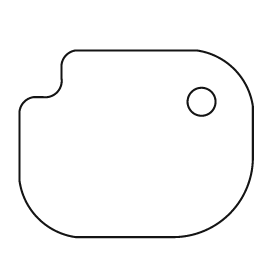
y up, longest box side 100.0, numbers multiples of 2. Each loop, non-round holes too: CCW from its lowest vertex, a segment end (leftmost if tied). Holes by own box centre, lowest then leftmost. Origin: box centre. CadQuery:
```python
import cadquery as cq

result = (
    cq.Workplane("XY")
    .moveTo(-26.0, -40.0)
    .lineTo(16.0, -40.0)
    .threePointArc((40.0, -30.0), (50.0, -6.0))
    .lineTo(50.0, 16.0)
    .threePointArc((42.0, 32.0), (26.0, 40.0))
    .lineTo(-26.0, 40.0)
    .threePointArc((-30.0, 38.0), (-32.0, 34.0))
    .lineTo(-32.0, 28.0)
    .threePointArc((-34.0, 22.0), (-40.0, 20.0))
    .lineTo(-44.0, 20.0)
    .threePointArc((-48.0, 18.0), (-50.0, 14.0))
    .lineTo(-50.0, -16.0)
    .threePointArc((-42.0, -32.0), (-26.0, -40.0))
    .close()
    .moveTo(28.0, 18.0)
    .circle(6.0)
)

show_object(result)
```